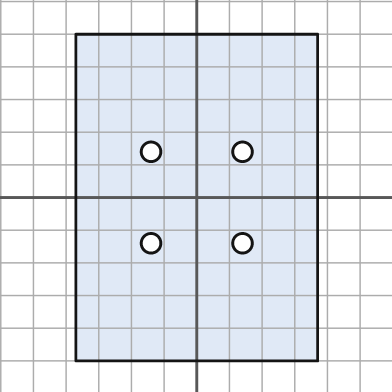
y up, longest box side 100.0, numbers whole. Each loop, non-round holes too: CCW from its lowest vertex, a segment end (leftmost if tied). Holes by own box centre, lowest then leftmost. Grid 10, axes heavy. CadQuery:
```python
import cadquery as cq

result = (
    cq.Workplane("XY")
    .moveTo(-37.0, -50.0)
    .lineTo(37.0, -50.0)
    .lineTo(37.0, 50.0)
    .lineTo(-37.0, 50.0)
    .close()
    .moveTo(-14.0, -14.0)
    .circle(3.0)
    .moveTo(14.0, -14.0)
    .circle(3.0)
    .moveTo(-14.0, 14.0)
    .circle(3.0)
    .moveTo(14.0, 14.0)
    .circle(3.0)
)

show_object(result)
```